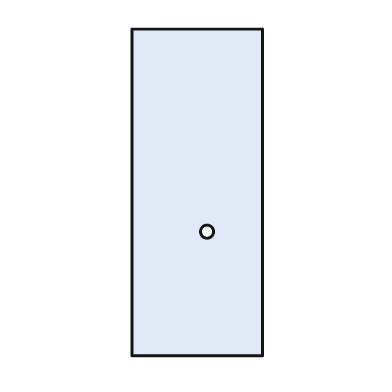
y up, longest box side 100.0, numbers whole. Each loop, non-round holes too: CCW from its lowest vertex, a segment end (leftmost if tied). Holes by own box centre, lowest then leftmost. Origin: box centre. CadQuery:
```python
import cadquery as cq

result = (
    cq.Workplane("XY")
    .moveTo(-20.0, -50.0)
    .lineTo(20.0, -50.0)
    .lineTo(20.0, 50.0)
    .lineTo(-20.0, 50.0)
    .close()
    .moveTo(3.0, -12.0)
    .circle(2.0)
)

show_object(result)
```